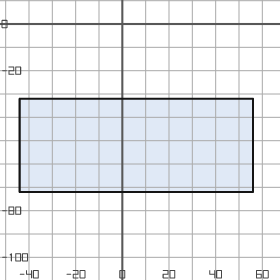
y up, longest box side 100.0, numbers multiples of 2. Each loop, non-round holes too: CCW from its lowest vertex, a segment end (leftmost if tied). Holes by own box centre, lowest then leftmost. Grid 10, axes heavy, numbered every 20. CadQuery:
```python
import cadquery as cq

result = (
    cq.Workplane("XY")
    .moveTo(-44.0, -72.0)
    .lineTo(56.0, -72.0)
    .lineTo(56.0, -32.0)
    .lineTo(-44.0, -32.0)
    .close()
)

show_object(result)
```